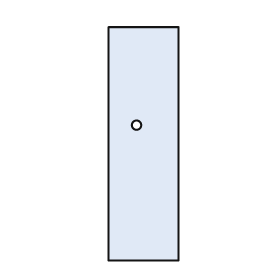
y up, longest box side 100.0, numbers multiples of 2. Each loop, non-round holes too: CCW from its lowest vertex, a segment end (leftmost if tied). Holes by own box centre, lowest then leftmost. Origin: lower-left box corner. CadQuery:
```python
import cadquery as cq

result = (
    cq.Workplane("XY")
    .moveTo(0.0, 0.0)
    .lineTo(30.0, 0.0)
    .lineTo(30.0, 100.0)
    .lineTo(0.0, 100.0)
    .close()
    .moveTo(12.0, 58.0)
    .circle(2.0)
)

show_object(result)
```